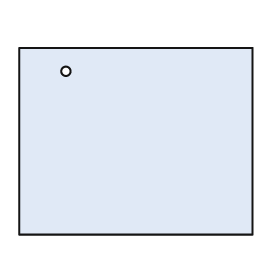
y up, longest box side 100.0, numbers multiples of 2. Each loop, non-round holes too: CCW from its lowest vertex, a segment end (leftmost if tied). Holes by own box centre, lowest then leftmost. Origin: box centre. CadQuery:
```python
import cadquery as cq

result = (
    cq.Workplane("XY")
    .moveTo(-50.0, -40.0)
    .lineTo(50.0, -40.0)
    .lineTo(50.0, 40.0)
    .lineTo(-50.0, 40.0)
    .close()
    .moveTo(-30.0, 30.0)
    .circle(2.0)
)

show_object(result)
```